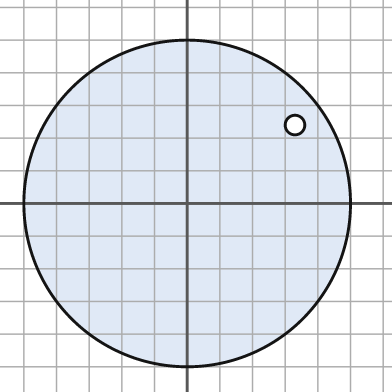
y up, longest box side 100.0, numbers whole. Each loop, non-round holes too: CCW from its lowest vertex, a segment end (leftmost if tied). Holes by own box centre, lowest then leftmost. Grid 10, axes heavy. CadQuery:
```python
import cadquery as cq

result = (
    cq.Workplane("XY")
    .moveTo(0.0, 0.0)
    .circle(50.0)
    .moveTo(33.0, 24.0)
    .circle(3.0)
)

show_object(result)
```